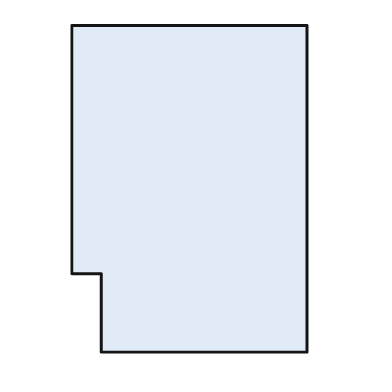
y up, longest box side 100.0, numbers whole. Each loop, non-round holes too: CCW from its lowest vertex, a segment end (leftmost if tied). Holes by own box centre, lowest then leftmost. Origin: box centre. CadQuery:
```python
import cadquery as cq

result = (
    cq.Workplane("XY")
    .moveTo(-27.0, -50.0)
    .lineTo(36.0, -50.0)
    .lineTo(36.0, 50.0)
    .lineTo(-36.0, 50.0)
    .lineTo(-36.0, -26.0)
    .lineTo(-27.0, -26.0)
    .close()
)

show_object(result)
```